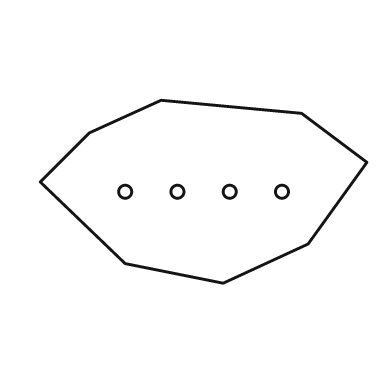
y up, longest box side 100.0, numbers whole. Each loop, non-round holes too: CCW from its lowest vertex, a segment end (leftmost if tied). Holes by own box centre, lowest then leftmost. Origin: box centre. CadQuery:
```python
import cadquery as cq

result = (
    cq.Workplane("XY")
    .moveTo(6.0, -28.0)
    .lineTo(32.0, -16.0)
    .lineTo(50.0, 9.0)
    .lineTo(30.0, 24.0)
    .lineTo(-13.0, 28.0)
    .lineTo(-35.0, 18.0)
    .lineTo(-50.0, 3.0)
    .lineTo(-24.0, -22.0)
    .close()
    .moveTo(-24.0, 0.0)
    .circle(2.0)
    .moveTo(-8.0, 0.0)
    .circle(2.0)
    .moveTo(8.0, 0.0)
    .circle(2.0)
    .moveTo(24.0, 0.0)
    .circle(2.0)
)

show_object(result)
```